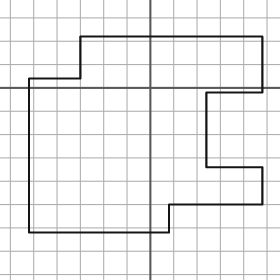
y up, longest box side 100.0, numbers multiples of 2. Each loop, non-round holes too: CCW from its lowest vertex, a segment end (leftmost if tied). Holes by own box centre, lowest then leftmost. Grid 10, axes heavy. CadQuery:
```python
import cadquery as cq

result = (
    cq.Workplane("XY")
    .moveTo(-52.0, -62.0)
    .lineTo(8.0, -62.0)
    .lineTo(8.0, -50.0)
    .lineTo(48.0, -50.0)
    .lineTo(48.0, -34.0)
    .lineTo(24.0, -34.0)
    .lineTo(24.0, -2.0)
    .lineTo(48.0, -2.0)
    .lineTo(48.0, 22.0)
    .lineTo(-30.0, 22.0)
    .lineTo(-30.0, 4.0)
    .lineTo(-52.0, 4.0)
    .close()
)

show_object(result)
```